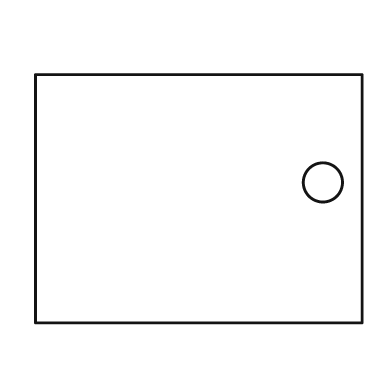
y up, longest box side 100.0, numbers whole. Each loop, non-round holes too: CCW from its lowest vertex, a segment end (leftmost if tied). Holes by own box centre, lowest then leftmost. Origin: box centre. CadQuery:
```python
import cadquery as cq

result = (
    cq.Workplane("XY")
    .moveTo(-50.0, -38.0)
    .lineTo(50.0, -38.0)
    .lineTo(50.0, 38.0)
    .lineTo(-50.0, 38.0)
    .close()
    .moveTo(38.0, 5.0)
    .circle(6.0)
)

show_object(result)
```